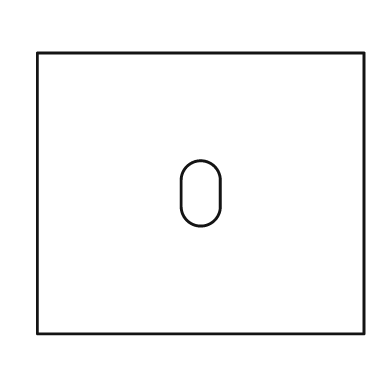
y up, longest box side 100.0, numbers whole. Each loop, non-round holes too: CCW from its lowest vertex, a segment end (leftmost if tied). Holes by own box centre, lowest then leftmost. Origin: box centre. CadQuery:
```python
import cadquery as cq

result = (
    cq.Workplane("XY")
    .moveTo(-50.0, -43.0)
    .lineTo(50.0, -43.0)
    .lineTo(50.0, 43.0)
    .lineTo(-50.0, 43.0)
    .close()
    .moveTo(-6.0, -4.0)
    .threePointArc((0.0, -10.0), (6.0, -4.0))
    .lineTo(6.0, 4.0)
    .threePointArc((0.0, 10.0), (-6.0, 4.0))
    .close()
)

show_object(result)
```